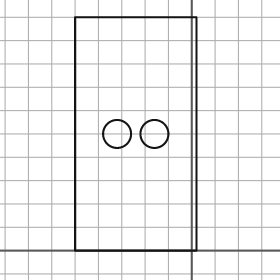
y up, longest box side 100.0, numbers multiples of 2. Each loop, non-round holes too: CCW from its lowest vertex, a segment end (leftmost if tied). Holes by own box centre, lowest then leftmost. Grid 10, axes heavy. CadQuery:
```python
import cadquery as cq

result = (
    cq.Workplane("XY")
    .moveTo(-50.0, 0.0)
    .lineTo(2.0, 0.0)
    .lineTo(2.0, 100.0)
    .lineTo(-50.0, 100.0)
    .close()
    .moveTo(-32.0, 50.0)
    .circle(6.0)
    .moveTo(-16.0, 50.0)
    .circle(6.0)
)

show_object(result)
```